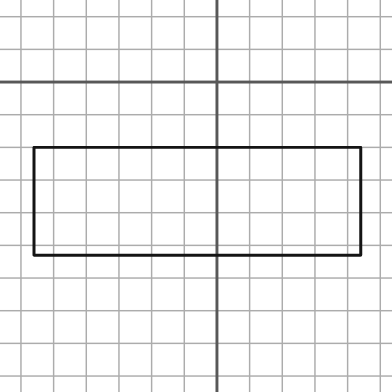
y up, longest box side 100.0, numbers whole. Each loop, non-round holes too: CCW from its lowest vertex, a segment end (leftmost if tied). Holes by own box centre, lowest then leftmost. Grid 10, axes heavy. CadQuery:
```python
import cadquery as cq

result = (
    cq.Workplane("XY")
    .moveTo(-56.0, -53.0)
    .lineTo(44.0, -53.0)
    .lineTo(44.0, -20.0)
    .lineTo(-56.0, -20.0)
    .close()
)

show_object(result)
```